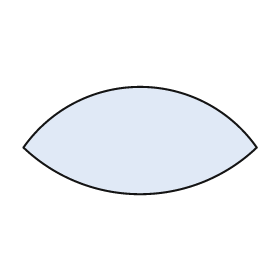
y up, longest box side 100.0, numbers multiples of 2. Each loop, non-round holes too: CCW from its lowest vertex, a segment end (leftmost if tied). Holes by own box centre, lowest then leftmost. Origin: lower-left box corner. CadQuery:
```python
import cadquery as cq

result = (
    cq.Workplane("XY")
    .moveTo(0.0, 20.0)
    .threePointArc((50.0, 0.0), (100.0, 20.0))
    .threePointArc((50.0, 46.0), (0.0, 20.0))
    .close()
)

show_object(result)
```